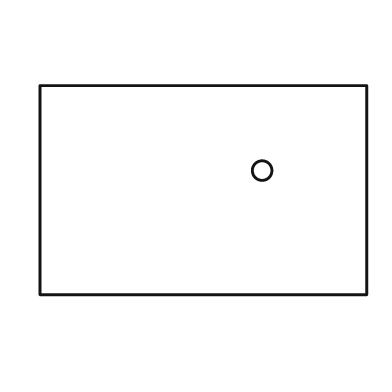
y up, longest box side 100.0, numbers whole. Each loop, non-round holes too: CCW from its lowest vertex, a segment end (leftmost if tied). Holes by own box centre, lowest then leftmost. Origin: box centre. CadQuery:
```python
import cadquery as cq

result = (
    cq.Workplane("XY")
    .moveTo(-50.0, -32.0)
    .lineTo(50.0, -32.0)
    .lineTo(50.0, 32.0)
    .lineTo(-50.0, 32.0)
    .close()
    .moveTo(18.0, 6.0)
    .circle(3.0)
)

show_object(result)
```